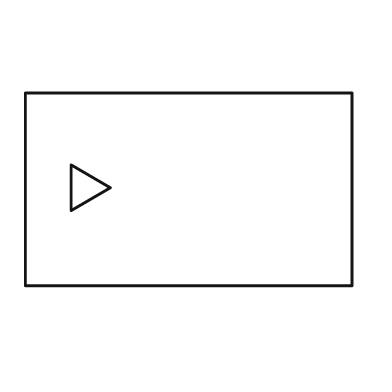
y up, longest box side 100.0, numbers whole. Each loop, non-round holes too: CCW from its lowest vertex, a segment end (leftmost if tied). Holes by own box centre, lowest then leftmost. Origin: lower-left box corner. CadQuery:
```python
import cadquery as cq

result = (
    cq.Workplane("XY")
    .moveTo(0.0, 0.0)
    .lineTo(100.0, 0.0)
    .lineTo(100.0, 59.0)
    .lineTo(0.0, 59.0)
    .close()
    .moveTo(14.0, 23.0)
    .lineTo(26.0, 30.0)
    .lineTo(14.0, 37.0)
    .close()
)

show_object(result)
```